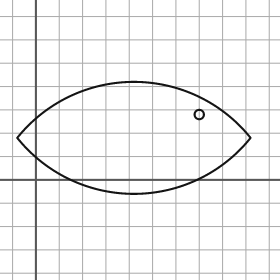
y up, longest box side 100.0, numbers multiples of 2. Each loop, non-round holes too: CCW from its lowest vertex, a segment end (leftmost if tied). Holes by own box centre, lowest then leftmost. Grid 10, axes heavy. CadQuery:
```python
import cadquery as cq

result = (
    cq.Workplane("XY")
    .moveTo(-8.0, 18.0)
    .threePointArc((42.0, -6.0), (92.0, 18.0))
    .threePointArc((42.0, 42.0), (-8.0, 18.0))
    .close()
    .moveTo(70.0, 28.0)
    .circle(2.0)
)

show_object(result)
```